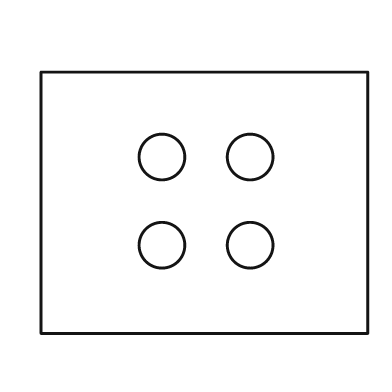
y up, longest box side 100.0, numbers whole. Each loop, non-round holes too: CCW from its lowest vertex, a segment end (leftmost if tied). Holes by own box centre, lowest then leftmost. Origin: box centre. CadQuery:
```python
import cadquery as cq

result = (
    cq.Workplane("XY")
    .moveTo(-50.0, -40.0)
    .lineTo(50.0, -40.0)
    .lineTo(50.0, 40.0)
    .lineTo(-50.0, 40.0)
    .close()
    .moveTo(-13.0, -13.0)
    .circle(7.0)
    .moveTo(14.0, -13.0)
    .circle(7.0)
    .moveTo(-13.0, 14.0)
    .circle(7.0)
    .moveTo(14.0, 14.0)
    .circle(7.0)
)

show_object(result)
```